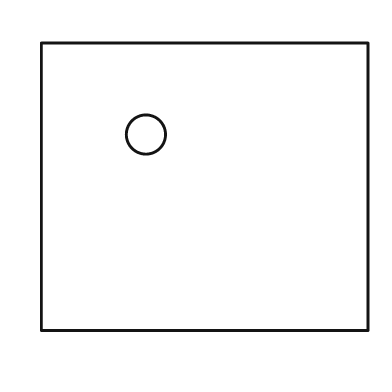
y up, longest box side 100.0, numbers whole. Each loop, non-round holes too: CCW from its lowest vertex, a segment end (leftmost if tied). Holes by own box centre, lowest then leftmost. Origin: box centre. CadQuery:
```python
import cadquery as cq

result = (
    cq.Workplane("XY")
    .moveTo(-50.0, -44.0)
    .lineTo(50.0, -44.0)
    .lineTo(50.0, 44.0)
    .lineTo(-50.0, 44.0)
    .close()
    .moveTo(-18.0, 16.0)
    .circle(6.0)
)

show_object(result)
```